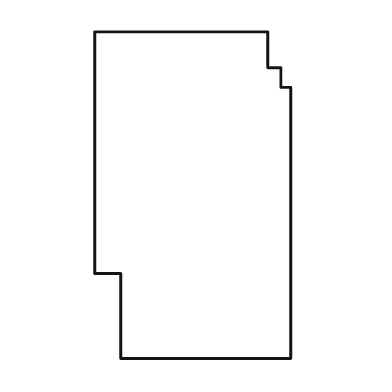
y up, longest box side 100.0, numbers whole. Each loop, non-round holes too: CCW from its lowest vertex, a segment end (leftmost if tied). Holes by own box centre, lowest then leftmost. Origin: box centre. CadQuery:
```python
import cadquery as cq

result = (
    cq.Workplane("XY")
    .moveTo(-22.0, -50.0)
    .lineTo(30.0, -50.0)
    .lineTo(30.0, 33.0)
    .lineTo(27.0, 33.0)
    .lineTo(27.0, 39.0)
    .lineTo(23.0, 39.0)
    .lineTo(23.0, 50.0)
    .lineTo(-30.0, 50.0)
    .lineTo(-30.0, -24.0)
    .lineTo(-22.0, -24.0)
    .close()
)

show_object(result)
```